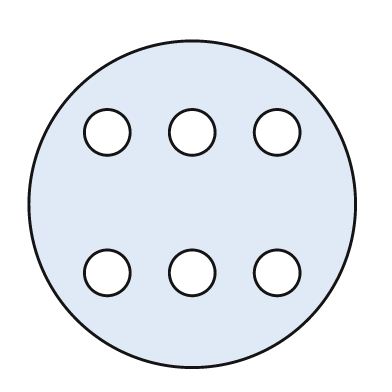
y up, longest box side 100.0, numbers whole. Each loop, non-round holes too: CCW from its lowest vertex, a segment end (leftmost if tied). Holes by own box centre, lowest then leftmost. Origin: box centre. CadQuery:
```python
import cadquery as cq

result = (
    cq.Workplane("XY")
    .moveTo(0.0, 0.0)
    .circle(50.0)
    .moveTo(-26.0, -21.0)
    .circle(7.0)
    .moveTo(0.0, -21.0)
    .circle(7.0)
    .moveTo(26.0, -21.0)
    .circle(7.0)
    .moveTo(-26.0, 22.0)
    .circle(7.0)
    .moveTo(0.0, 22.0)
    .circle(7.0)
    .moveTo(26.0, 22.0)
    .circle(7.0)
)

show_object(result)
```